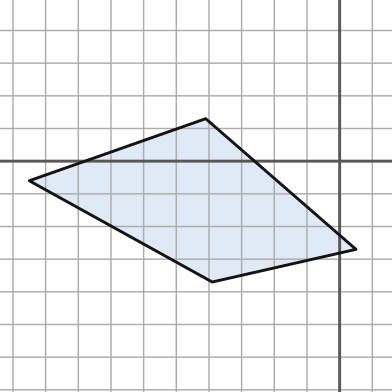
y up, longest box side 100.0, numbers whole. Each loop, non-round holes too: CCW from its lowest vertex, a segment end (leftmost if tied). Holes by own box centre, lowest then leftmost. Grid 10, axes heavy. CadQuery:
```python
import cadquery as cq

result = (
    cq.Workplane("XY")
    .moveTo(-39.0, -37.0)
    .lineTo(5.0, -27.0)
    .lineTo(-41.0, 13.0)
    .lineTo(-95.0, -6.0)
    .close()
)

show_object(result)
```